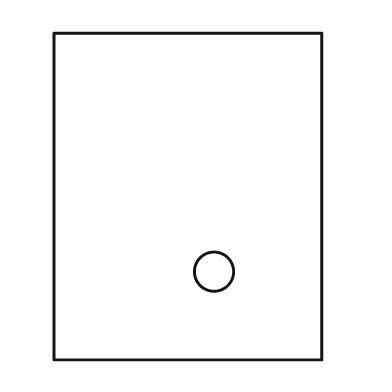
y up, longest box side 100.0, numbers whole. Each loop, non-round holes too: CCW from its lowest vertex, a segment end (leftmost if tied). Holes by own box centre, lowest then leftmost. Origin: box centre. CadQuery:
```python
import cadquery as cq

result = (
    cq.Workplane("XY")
    .moveTo(-41.0, -50.0)
    .lineTo(41.0, -50.0)
    .lineTo(41.0, 50.0)
    .lineTo(-41.0, 50.0)
    .close()
    .moveTo(8.0, -23.0)
    .circle(6.0)
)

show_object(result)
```